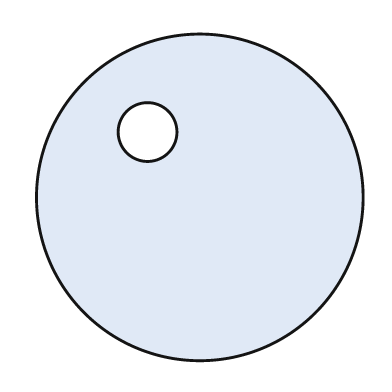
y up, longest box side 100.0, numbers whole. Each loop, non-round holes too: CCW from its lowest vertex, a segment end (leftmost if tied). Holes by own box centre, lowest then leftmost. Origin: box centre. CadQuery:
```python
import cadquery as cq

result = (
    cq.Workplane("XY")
    .moveTo(0.0, 0.0)
    .circle(50.0)
    .moveTo(-16.0, 20.0)
    .circle(9.0)
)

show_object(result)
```